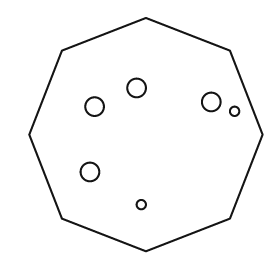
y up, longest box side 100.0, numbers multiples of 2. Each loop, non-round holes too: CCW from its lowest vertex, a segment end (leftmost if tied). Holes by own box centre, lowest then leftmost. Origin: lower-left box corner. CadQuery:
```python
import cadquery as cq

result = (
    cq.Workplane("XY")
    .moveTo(50.0, 0.0)
    .lineTo(86.0, 14.0)
    .lineTo(100.0, 50.0)
    .lineTo(86.0, 86.0)
    .lineTo(50.0, 100.0)
    .lineTo(14.0, 86.0)
    .lineTo(0.0, 50.0)
    .lineTo(14.0, 14.0)
    .close()
    .moveTo(48.0, 20.0)
    .circle(2.0)
    .moveTo(26.0, 34.0)
    .circle(4.0)
    .moveTo(88.0, 60.0)
    .circle(2.0)
    .moveTo(28.0, 62.0)
    .circle(4.0)
    .moveTo(78.0, 64.0)
    .circle(4.0)
    .moveTo(46.0, 70.0)
    .circle(4.0)
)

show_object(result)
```